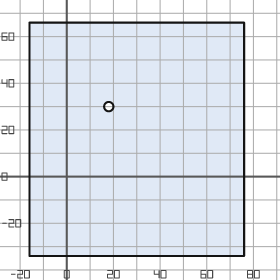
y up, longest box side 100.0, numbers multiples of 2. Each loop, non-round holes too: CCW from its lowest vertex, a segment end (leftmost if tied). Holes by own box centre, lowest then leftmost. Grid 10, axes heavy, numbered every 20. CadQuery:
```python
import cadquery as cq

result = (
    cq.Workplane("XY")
    .moveTo(-16.0, -34.0)
    .lineTo(76.0, -34.0)
    .lineTo(76.0, 66.0)
    .lineTo(-16.0, 66.0)
    .close()
    .moveTo(18.0, 30.0)
    .circle(2.0)
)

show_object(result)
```